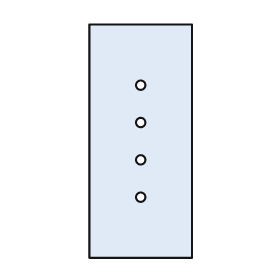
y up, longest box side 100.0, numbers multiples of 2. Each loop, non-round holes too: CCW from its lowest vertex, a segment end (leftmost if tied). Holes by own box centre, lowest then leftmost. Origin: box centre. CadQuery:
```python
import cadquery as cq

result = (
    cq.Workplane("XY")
    .moveTo(-22.0, -50.0)
    .lineTo(22.0, -50.0)
    .lineTo(22.0, 50.0)
    .lineTo(-22.0, 50.0)
    .close()
    .moveTo(0.0, -24.0)
    .circle(2.0)
    .moveTo(0.0, -8.0)
    .circle(2.0)
    .moveTo(0.0, 8.0)
    .circle(2.0)
    .moveTo(0.0, 24.0)
    .circle(2.0)
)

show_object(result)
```